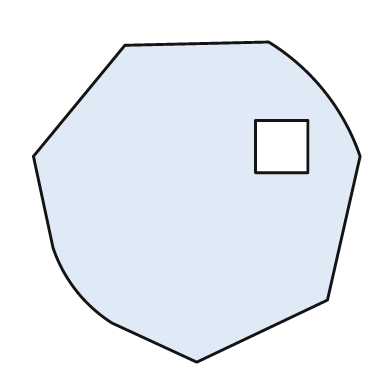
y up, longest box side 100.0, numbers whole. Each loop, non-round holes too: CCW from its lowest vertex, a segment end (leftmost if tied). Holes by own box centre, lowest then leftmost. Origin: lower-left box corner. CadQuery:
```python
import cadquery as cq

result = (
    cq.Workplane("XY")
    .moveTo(50.0, 0.0)
    .lineTo(90.0, 19.0)
    .lineTo(100.0, 63.0)
    .threePointArc((89.0, 83.0), (72.0, 98.0))
    .lineTo(28.0, 97.0)
    .lineTo(0.0, 63.0)
    .lineTo(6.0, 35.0)
    .threePointArc((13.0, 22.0), (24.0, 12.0))
    .close()
    .moveTo(68.0, 58.0)
    .lineTo(84.0, 58.0)
    .lineTo(84.0, 74.0)
    .lineTo(68.0, 74.0)
    .close()
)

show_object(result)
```